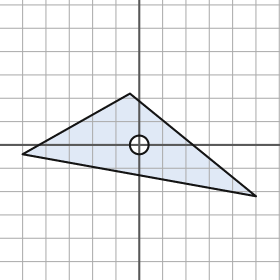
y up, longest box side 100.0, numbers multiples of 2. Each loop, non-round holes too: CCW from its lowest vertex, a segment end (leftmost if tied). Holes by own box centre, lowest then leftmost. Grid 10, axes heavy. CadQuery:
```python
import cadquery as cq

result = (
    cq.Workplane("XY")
    .moveTo(50.0, -22.0)
    .lineTo(-4.0, 22.0)
    .lineTo(-50.0, -4.0)
    .close()
    .moveTo(0.0, 0.0)
    .circle(4.0)
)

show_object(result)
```